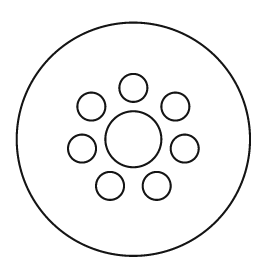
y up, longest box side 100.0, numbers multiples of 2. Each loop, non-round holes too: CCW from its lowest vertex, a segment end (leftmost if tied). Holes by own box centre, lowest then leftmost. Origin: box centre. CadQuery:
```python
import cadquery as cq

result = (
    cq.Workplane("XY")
    .moveTo(0.0, 0.0)
    .circle(50.0)
    .moveTo(-10.0, -20.0)
    .circle(6.0)
    .moveTo(10.0, -20.0)
    .circle(6.0)
    .moveTo(-22.0, -4.0)
    .circle(6.0)
    .moveTo(22.0, -4.0)
    .circle(6.0)
    .moveTo(0.0, 0.0)
    .circle(12.0)
    .moveTo(-18.0, 14.0)
    .circle(6.0)
    .moveTo(18.0, 14.0)
    .circle(6.0)
    .moveTo(0.0, 22.0)
    .circle(6.0)
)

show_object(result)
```